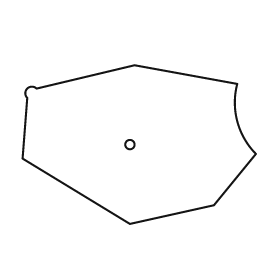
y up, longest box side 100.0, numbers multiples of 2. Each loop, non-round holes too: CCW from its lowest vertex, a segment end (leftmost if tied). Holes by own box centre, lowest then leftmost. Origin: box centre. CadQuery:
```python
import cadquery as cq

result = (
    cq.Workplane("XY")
    .moveTo(-4.0, -34.0)
    .lineTo(32.0, -26.0)
    .lineTo(50.0, -4.0)
    .threePointArc((42.0, 10.0), (42.0, 26.0))
    .lineTo(-2.0, 34.0)
    .lineTo(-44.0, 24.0)
    .threePointArc((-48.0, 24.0), (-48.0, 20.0))
    .lineTo(-50.0, -6.0)
    .close()
    .moveTo(-4.0, 0.0)
    .circle(2.0)
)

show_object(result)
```